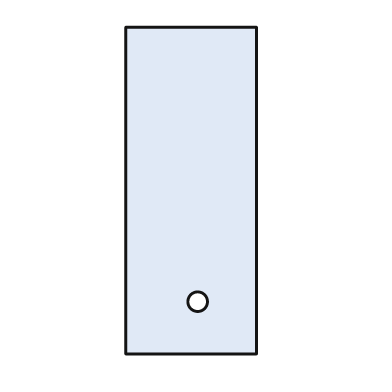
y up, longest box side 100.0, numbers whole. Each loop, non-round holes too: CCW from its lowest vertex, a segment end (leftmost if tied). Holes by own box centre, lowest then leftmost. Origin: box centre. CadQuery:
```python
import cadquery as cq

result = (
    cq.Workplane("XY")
    .moveTo(-20.0, -50.0)
    .lineTo(20.0, -50.0)
    .lineTo(20.0, 50.0)
    .lineTo(-20.0, 50.0)
    .close()
    .moveTo(2.0, -34.0)
    .circle(3.0)
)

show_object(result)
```